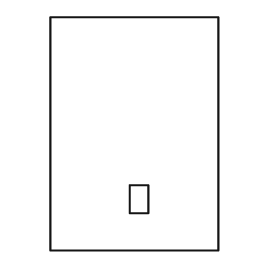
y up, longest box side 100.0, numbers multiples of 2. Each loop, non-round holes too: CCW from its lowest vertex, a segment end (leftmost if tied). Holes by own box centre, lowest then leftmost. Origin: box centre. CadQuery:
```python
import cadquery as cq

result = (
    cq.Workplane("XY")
    .moveTo(-36.0, -50.0)
    .lineTo(36.0, -50.0)
    .lineTo(36.0, 50.0)
    .lineTo(-36.0, 50.0)
    .close()
    .moveTo(-2.0, -34.0)
    .lineTo(6.0, -34.0)
    .lineTo(6.0, -22.0)
    .lineTo(-2.0, -22.0)
    .close()
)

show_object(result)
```